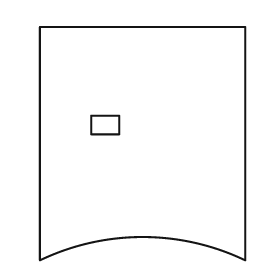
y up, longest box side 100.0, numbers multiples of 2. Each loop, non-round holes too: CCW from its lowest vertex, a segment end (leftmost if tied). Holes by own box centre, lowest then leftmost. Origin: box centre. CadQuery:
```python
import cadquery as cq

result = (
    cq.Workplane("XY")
    .moveTo(-44.0, -50.0)
    .threePointArc((0.0, -40.0), (44.0, -50.0))
    .lineTo(44.0, 50.0)
    .lineTo(-44.0, 50.0)
    .close()
    .moveTo(-22.0, 4.0)
    .lineTo(-10.0, 4.0)
    .lineTo(-10.0, 12.0)
    .lineTo(-22.0, 12.0)
    .close()
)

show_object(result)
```